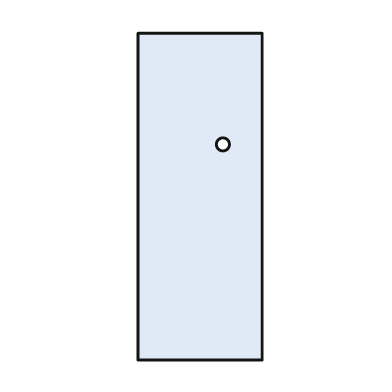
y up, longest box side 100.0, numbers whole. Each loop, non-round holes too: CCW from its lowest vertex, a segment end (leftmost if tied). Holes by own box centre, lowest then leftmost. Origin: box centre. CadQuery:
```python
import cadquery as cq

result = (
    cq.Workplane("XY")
    .moveTo(-19.0, -50.0)
    .lineTo(19.0, -50.0)
    .lineTo(19.0, 50.0)
    .lineTo(-19.0, 50.0)
    .close()
    .moveTo(7.0, 16.0)
    .circle(2.0)
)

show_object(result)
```